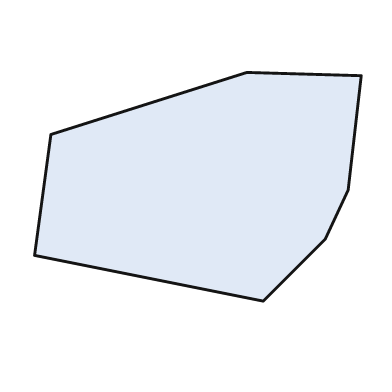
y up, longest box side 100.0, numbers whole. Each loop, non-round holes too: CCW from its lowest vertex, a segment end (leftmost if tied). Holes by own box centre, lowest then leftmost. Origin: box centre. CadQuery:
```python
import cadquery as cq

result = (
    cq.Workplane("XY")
    .moveTo(20.0, -35.0)
    .lineTo(39.0, -16.0)
    .lineTo(46.0, -1.0)
    .lineTo(50.0, 34.0)
    .lineTo(15.0, 35.0)
    .lineTo(-45.0, 16.0)
    .lineTo(-50.0, -21.0)
    .close()
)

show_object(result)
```